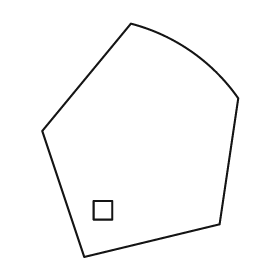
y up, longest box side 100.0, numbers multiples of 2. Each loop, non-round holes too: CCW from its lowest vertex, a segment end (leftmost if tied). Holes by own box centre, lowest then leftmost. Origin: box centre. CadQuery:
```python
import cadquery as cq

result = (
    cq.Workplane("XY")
    .moveTo(-24.0, -50.0)
    .lineTo(34.0, -36.0)
    .lineTo(42.0, 18.0)
    .threePointArc((22.0, 38.0), (-4.0, 50.0))
    .lineTo(-42.0, 4.0)
    .close()
    .moveTo(-20.0, -34.0)
    .lineTo(-12.0, -34.0)
    .lineTo(-12.0, -26.0)
    .lineTo(-20.0, -26.0)
    .close()
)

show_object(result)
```